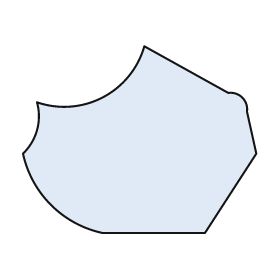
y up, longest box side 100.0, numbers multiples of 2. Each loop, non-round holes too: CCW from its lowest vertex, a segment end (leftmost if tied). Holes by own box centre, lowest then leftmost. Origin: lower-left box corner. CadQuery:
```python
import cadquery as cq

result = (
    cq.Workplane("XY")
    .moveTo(34.0, 0.0)
    .lineTo(78.0, 0.0)
    .lineTo(100.0, 34.0)
    .lineTo(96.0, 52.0)
    .threePointArc((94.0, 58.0), (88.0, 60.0))
    .lineTo(52.0, 80.0)
    .threePointArc((34.0, 58.0), (6.0, 56.0))
    .threePointArc((6.0, 44.0), (0.0, 34.0))
    .threePointArc((12.0, 12.0), (34.0, 0.0))
    .close()
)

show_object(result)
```